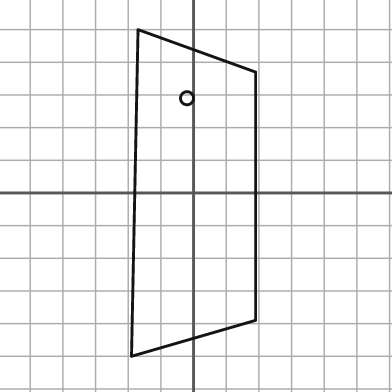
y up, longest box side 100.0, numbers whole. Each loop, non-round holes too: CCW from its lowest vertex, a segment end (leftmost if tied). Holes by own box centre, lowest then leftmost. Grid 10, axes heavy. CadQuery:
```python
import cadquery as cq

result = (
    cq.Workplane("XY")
    .moveTo(-19.0, -50.0)
    .lineTo(19.0, -39.0)
    .lineTo(19.0, 37.0)
    .lineTo(-17.0, 50.0)
    .close()
    .moveTo(-2.0, 29.0)
    .circle(2.0)
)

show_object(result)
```